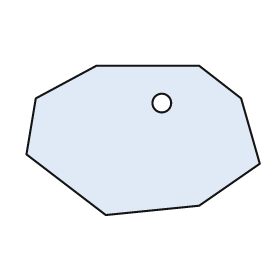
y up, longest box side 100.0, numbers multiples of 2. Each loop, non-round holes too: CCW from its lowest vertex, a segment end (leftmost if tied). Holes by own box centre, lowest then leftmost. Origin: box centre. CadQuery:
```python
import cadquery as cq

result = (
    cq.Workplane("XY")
    .moveTo(-16.0, -32.0)
    .lineTo(24.0, -28.0)
    .lineTo(50.0, -10.0)
    .lineTo(42.0, 18.0)
    .lineTo(24.0, 32.0)
    .lineTo(-20.0, 32.0)
    .lineTo(-46.0, 18.0)
    .lineTo(-50.0, -6.0)
    .close()
    .moveTo(8.0, 16.0)
    .circle(4.0)
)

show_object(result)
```